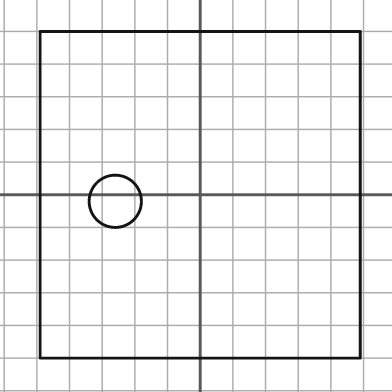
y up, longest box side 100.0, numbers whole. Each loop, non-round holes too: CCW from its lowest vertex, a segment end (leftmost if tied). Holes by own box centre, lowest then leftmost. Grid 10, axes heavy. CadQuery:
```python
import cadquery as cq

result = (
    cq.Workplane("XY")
    .moveTo(-49.0, -50.0)
    .lineTo(49.0, -50.0)
    .lineTo(49.0, 50.0)
    .lineTo(-49.0, 50.0)
    .close()
    .moveTo(-26.0, -2.0)
    .circle(8.0)
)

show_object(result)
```